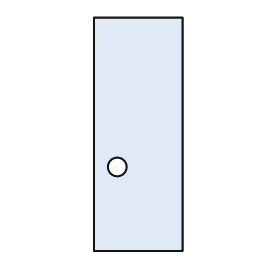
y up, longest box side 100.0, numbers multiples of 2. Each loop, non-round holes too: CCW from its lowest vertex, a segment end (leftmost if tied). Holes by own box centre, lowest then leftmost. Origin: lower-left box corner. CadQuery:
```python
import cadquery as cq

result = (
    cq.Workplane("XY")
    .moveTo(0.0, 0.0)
    .lineTo(38.0, 0.0)
    .lineTo(38.0, 100.0)
    .lineTo(0.0, 100.0)
    .close()
    .moveTo(10.0, 36.0)
    .circle(4.0)
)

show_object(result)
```